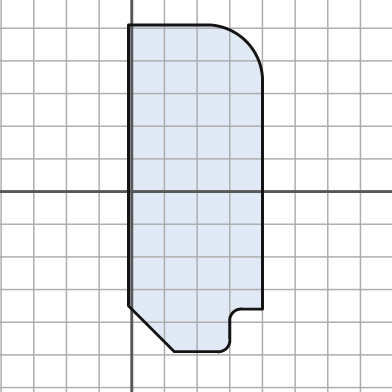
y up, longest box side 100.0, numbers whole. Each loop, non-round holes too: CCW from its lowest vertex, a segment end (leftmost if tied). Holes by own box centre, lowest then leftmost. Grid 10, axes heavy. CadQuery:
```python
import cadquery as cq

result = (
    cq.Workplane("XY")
    .moveTo(13.0, -49.0)
    .lineTo(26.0, -49.0)
    .threePointArc((29.0, -48.0), (30.0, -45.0))
    .lineTo(30.0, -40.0)
    .threePointArc((31.0, -37.0), (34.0, -36.0))
    .lineTo(40.0, -36.0)
    .lineTo(40.0, 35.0)
    .threePointArc((35.0, 46.0), (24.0, 51.0))
    .lineTo(-1.0, 51.0)
    .lineTo(-1.0, -35.0)
    .close()
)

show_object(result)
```